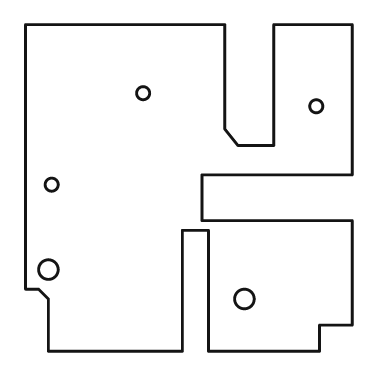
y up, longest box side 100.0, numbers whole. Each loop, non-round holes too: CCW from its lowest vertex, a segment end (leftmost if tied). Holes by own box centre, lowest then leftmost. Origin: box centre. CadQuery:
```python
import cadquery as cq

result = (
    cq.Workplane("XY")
    .moveTo(-43.0, -50.0)
    .lineTo(-2.0, -50.0)
    .lineTo(-2.0, -13.0)
    .lineTo(6.0, -13.0)
    .lineTo(6.0, -50.0)
    .lineTo(40.0, -50.0)
    .lineTo(40.0, -42.0)
    .lineTo(50.0, -42.0)
    .lineTo(50.0, -10.0)
    .lineTo(4.0, -10.0)
    .lineTo(4.0, 4.0)
    .lineTo(50.0, 4.0)
    .lineTo(50.0, 50.0)
    .lineTo(26.0, 50.0)
    .lineTo(26.0, 13.0)
    .lineTo(15.0, 13.0)
    .lineTo(11.0, 18.0)
    .lineTo(11.0, 50.0)
    .lineTo(-50.0, 50.0)
    .lineTo(-50.0, -31.0)
    .lineTo(-46.0, -31.0)
    .lineTo(-43.0, -34.0)
    .close()
    .moveTo(17.0, -34.0)
    .circle(3.0)
    .moveTo(-43.0, -25.0)
    .circle(3.0)
    .moveTo(-42.0, 1.0)
    .circle(2.0)
    .moveTo(39.0, 25.0)
    .circle(2.0)
    .moveTo(-14.0, 29.0)
    .circle(2.0)
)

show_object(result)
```